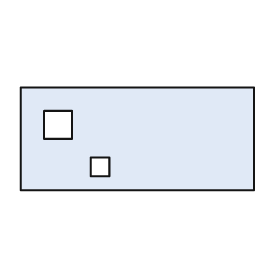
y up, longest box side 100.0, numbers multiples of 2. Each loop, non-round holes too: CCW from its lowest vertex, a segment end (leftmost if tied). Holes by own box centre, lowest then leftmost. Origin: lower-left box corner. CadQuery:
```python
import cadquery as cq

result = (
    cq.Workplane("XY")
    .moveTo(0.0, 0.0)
    .lineTo(100.0, 0.0)
    .lineTo(100.0, 44.0)
    .lineTo(0.0, 44.0)
    .close()
    .moveTo(30.0, 6.0)
    .lineTo(38.0, 6.0)
    .lineTo(38.0, 14.0)
    .lineTo(30.0, 14.0)
    .close()
    .moveTo(10.0, 22.0)
    .lineTo(22.0, 22.0)
    .lineTo(22.0, 34.0)
    .lineTo(10.0, 34.0)
    .close()
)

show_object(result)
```